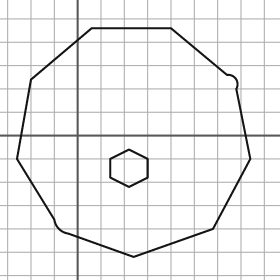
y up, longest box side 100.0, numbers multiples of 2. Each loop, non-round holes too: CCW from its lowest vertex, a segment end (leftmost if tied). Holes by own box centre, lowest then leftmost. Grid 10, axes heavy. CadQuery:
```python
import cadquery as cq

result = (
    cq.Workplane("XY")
    .moveTo(24.0, -52.0)
    .lineTo(58.0, -40.0)
    .lineTo(74.0, -10.0)
    .lineTo(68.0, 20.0)
    .threePointArc((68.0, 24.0), (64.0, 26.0))
    .lineTo(40.0, 46.0)
    .lineTo(6.0, 46.0)
    .lineTo(-20.0, 24.0)
    .lineTo(-26.0, -10.0)
    .lineTo(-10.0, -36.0)
    .threePointArc((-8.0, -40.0), (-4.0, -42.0))
    .close()
    .moveTo(22.0, -22.0)
    .lineTo(30.0, -18.0)
    .lineTo(30.0, -10.0)
    .lineTo(22.0, -6.0)
    .lineTo(14.0, -10.0)
    .lineTo(14.0, -18.0)
    .close()
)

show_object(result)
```